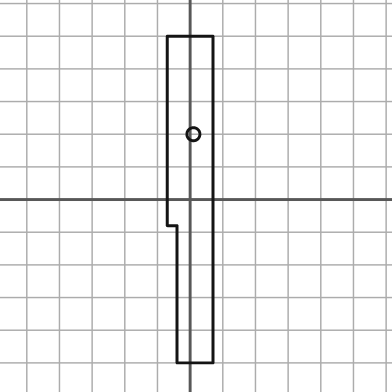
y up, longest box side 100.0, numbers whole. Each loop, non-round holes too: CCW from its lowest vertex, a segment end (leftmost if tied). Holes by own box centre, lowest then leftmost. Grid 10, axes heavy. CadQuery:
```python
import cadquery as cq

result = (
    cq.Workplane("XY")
    .moveTo(-4.0, -50.0)
    .lineTo(7.0, -50.0)
    .lineTo(7.0, 50.0)
    .lineTo(-7.0, 50.0)
    .lineTo(-7.0, -8.0)
    .lineTo(-4.0, -8.0)
    .close()
    .moveTo(1.0, 20.0)
    .circle(2.0)
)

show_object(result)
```